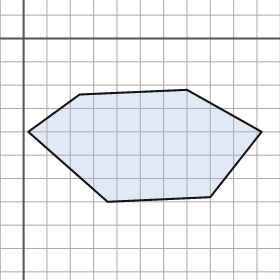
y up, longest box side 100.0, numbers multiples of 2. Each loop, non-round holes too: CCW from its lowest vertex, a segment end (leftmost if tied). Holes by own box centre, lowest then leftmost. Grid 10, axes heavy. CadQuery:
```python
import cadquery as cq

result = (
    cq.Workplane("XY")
    .moveTo(36.0, -70.0)
    .lineTo(80.0, -68.0)
    .lineTo(102.0, -40.0)
    .lineTo(70.0, -22.0)
    .lineTo(24.0, -24.0)
    .lineTo(2.0, -40.0)
    .close()
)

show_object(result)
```